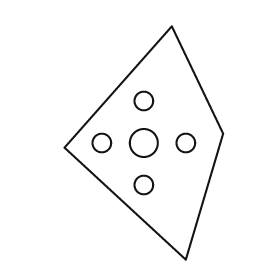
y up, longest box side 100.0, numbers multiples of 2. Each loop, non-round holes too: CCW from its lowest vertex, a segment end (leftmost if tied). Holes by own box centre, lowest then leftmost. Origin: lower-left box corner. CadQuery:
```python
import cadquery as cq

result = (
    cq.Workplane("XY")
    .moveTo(52.0, 0.0)
    .lineTo(68.0, 54.0)
    .lineTo(46.0, 100.0)
    .lineTo(0.0, 48.0)
    .close()
    .moveTo(34.0, 32.0)
    .circle(4.0)
    .moveTo(16.0, 50.0)
    .circle(4.0)
    .moveTo(34.0, 50.0)
    .circle(6.0)
    .moveTo(52.0, 50.0)
    .circle(4.0)
    .moveTo(34.0, 68.0)
    .circle(4.0)
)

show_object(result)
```